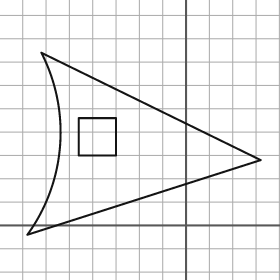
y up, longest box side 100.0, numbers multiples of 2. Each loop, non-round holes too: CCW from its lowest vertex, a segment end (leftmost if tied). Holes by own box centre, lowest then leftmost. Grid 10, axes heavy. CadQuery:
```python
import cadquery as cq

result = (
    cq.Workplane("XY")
    .moveTo(-68.0, -4.0)
    .lineTo(32.0, 28.0)
    .lineTo(-62.0, 74.0)
    .threePointArc((-54.0, 34.0), (-68.0, -4.0))
    .close()
    .moveTo(-46.0, 30.0)
    .lineTo(-30.0, 30.0)
    .lineTo(-30.0, 46.0)
    .lineTo(-46.0, 46.0)
    .close()
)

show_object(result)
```